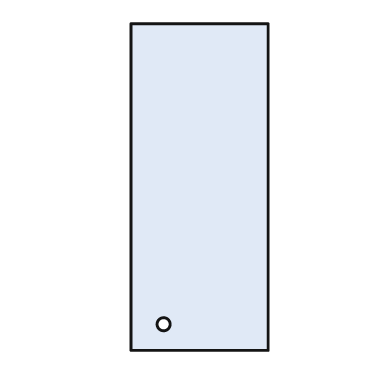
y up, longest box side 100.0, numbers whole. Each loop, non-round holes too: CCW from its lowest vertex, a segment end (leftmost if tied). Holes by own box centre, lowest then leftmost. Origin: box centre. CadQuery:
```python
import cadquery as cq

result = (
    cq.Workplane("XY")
    .moveTo(-21.0, -50.0)
    .lineTo(21.0, -50.0)
    .lineTo(21.0, 50.0)
    .lineTo(-21.0, 50.0)
    .close()
    .moveTo(-11.0, -42.0)
    .circle(2.0)
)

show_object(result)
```